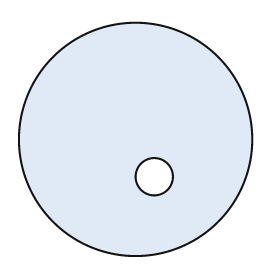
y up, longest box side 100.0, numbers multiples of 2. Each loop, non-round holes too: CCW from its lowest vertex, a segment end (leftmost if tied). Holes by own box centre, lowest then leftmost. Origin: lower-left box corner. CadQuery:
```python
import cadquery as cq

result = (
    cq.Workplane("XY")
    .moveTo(50.0, 50.0)
    .circle(50.0)
    .moveTo(58.0, 34.0)
    .circle(8.0)
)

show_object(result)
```